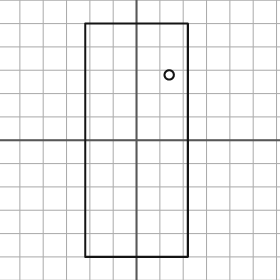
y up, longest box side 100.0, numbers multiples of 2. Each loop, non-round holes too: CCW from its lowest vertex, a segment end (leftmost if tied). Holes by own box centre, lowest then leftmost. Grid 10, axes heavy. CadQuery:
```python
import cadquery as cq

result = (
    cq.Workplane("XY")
    .moveTo(-22.0, -50.0)
    .lineTo(22.0, -50.0)
    .lineTo(22.0, 50.0)
    .lineTo(-22.0, 50.0)
    .close()
    .moveTo(14.0, 28.0)
    .circle(2.0)
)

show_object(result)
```